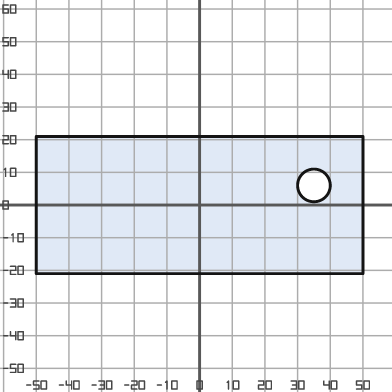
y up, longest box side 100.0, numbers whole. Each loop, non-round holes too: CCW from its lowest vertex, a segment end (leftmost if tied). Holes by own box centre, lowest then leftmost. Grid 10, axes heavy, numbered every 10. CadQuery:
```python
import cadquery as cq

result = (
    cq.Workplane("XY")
    .moveTo(-50.0, -21.0)
    .lineTo(50.0, -21.0)
    .lineTo(50.0, 21.0)
    .lineTo(-50.0, 21.0)
    .close()
    .moveTo(35.0, 6.0)
    .circle(5.0)
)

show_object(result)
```